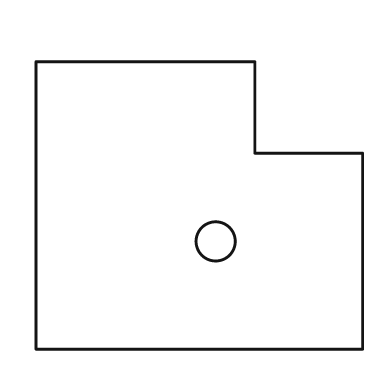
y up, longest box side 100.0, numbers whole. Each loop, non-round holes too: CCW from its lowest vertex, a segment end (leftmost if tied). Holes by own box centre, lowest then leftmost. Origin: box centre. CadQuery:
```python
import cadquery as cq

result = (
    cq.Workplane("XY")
    .moveTo(-50.0, -44.0)
    .lineTo(50.0, -44.0)
    .lineTo(50.0, 16.0)
    .lineTo(17.0, 16.0)
    .lineTo(17.0, 44.0)
    .lineTo(-50.0, 44.0)
    .close()
    .moveTo(5.0, -11.0)
    .circle(6.0)
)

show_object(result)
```